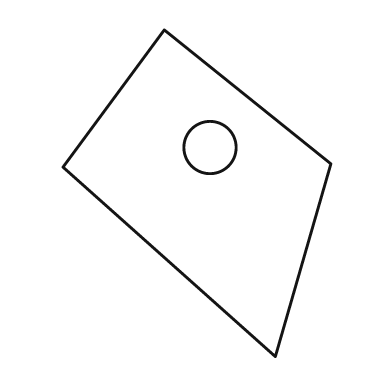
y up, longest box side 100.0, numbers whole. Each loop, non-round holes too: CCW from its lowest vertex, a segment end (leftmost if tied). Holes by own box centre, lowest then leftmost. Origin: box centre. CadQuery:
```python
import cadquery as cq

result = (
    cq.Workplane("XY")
    .moveTo(24.0, -50.0)
    .lineTo(41.0, 9.0)
    .lineTo(-10.0, 50.0)
    .lineTo(-41.0, 8.0)
    .close()
    .moveTo(4.0, 14.0)
    .circle(8.0)
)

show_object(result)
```